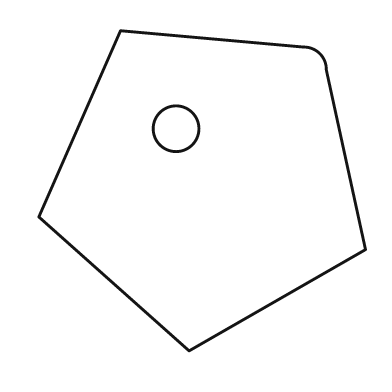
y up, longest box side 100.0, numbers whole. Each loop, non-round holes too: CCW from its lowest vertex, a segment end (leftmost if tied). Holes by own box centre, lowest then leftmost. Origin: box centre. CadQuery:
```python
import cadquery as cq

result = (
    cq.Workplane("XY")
    .moveTo(-4.0, -49.0)
    .lineTo(50.0, -18.0)
    .lineTo(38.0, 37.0)
    .threePointArc((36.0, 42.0), (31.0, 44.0))
    .lineTo(-25.0, 49.0)
    .lineTo(-50.0, -8.0)
    .close()
    .moveTo(-8.0, 19.0)
    .circle(7.0)
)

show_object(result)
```